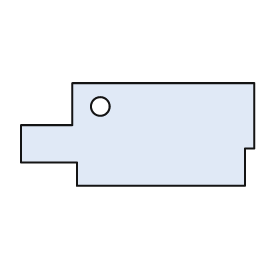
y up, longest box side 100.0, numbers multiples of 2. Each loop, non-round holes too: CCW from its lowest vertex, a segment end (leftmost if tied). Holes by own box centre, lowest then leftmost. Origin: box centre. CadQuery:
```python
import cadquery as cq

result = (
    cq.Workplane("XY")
    .moveTo(-26.0, -22.0)
    .lineTo(46.0, -22.0)
    .lineTo(46.0, -6.0)
    .lineTo(50.0, -6.0)
    .lineTo(50.0, 22.0)
    .lineTo(-28.0, 22.0)
    .lineTo(-28.0, 4.0)
    .lineTo(-50.0, 4.0)
    .lineTo(-50.0, -12.0)
    .lineTo(-26.0, -12.0)
    .close()
    .moveTo(-16.0, 12.0)
    .circle(4.0)
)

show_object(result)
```